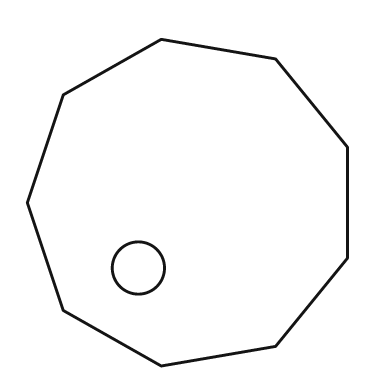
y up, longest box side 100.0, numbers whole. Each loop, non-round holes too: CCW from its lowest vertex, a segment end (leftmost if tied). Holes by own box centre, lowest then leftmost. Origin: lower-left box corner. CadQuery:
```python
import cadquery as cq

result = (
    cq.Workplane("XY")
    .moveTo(41.0, 0.0)
    .lineTo(76.0, 6.0)
    .lineTo(98.0, 33.0)
    .lineTo(98.0, 67.0)
    .lineTo(76.0, 94.0)
    .lineTo(41.0, 100.0)
    .lineTo(11.0, 83.0)
    .lineTo(0.0, 50.0)
    .lineTo(11.0, 17.0)
    .close()
    .moveTo(34.0, 30.0)
    .circle(8.0)
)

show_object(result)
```